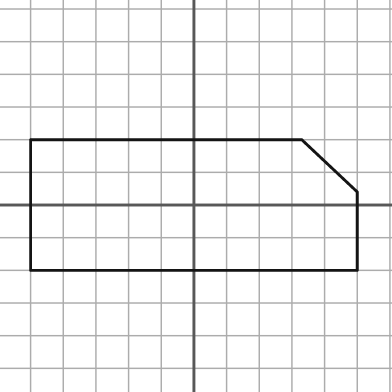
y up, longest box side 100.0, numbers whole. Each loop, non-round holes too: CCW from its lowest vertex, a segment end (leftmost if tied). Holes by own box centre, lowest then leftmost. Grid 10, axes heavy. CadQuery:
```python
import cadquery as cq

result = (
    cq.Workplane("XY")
    .moveTo(-50.0, -20.0)
    .lineTo(50.0, -20.0)
    .lineTo(50.0, 4.0)
    .lineTo(33.0, 20.0)
    .lineTo(-50.0, 20.0)
    .close()
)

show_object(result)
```